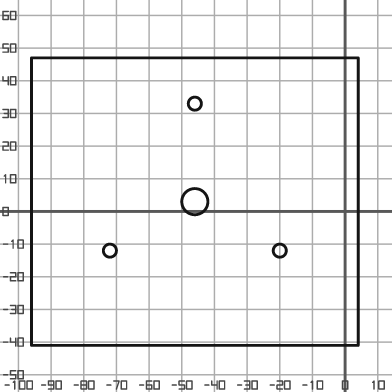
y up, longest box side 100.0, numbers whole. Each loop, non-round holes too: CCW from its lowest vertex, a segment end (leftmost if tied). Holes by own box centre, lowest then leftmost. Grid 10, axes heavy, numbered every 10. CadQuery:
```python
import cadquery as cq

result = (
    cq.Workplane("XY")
    .moveTo(-96.0, -41.0)
    .lineTo(4.0, -41.0)
    .lineTo(4.0, 47.0)
    .lineTo(-96.0, 47.0)
    .close()
    .moveTo(-72.0, -12.0)
    .circle(2.0)
    .moveTo(-20.0, -12.0)
    .circle(2.0)
    .moveTo(-46.0, 3.0)
    .circle(4.0)
    .moveTo(-46.0, 33.0)
    .circle(2.0)
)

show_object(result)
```